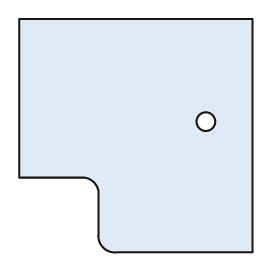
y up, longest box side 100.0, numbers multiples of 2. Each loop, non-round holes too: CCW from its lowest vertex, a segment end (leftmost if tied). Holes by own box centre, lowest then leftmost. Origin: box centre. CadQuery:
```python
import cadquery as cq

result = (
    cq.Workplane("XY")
    .moveTo(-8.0, -50.0)
    .lineTo(50.0, -50.0)
    .lineTo(50.0, 50.0)
    .lineTo(-50.0, 50.0)
    .lineTo(-50.0, -18.0)
    .lineTo(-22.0, -18.0)
    .threePointArc((-18.0, -20.0), (-16.0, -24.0))
    .lineTo(-16.0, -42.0)
    .threePointArc((-14.0, -48.0), (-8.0, -50.0))
    .close()
    .moveTo(30.0, 6.0)
    .circle(4.0)
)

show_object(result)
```